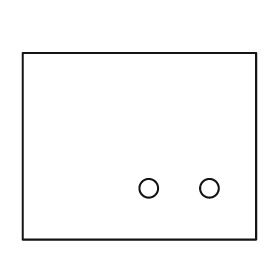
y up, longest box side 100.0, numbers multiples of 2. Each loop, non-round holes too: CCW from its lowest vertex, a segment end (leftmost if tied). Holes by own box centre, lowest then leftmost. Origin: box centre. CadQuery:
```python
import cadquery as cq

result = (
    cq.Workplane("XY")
    .moveTo(-50.0, -40.0)
    .lineTo(50.0, -40.0)
    .lineTo(50.0, 40.0)
    .lineTo(-50.0, 40.0)
    .close()
    .moveTo(4.0, -18.0)
    .circle(4.0)
    .moveTo(30.0, -18.0)
    .circle(4.0)
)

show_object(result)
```